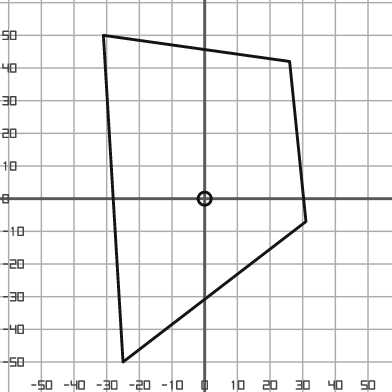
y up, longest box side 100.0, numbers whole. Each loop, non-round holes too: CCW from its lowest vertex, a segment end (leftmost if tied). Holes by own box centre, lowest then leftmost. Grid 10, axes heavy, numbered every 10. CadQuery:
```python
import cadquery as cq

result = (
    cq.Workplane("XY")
    .moveTo(-25.0, -50.0)
    .lineTo(31.0, -7.0)
    .lineTo(26.0, 42.0)
    .lineTo(-31.0, 50.0)
    .close()
    .moveTo(0.0, 0.0)
    .circle(2.0)
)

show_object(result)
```